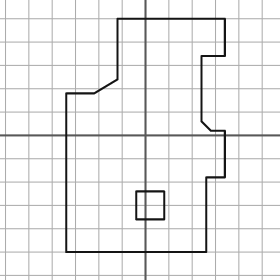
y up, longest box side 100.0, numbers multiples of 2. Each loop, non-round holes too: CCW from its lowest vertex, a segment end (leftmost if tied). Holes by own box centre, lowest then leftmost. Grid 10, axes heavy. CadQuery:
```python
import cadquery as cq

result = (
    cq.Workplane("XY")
    .moveTo(-34.0, -50.0)
    .lineTo(26.0, -50.0)
    .lineTo(26.0, -18.0)
    .lineTo(34.0, -18.0)
    .lineTo(34.0, 2.0)
    .lineTo(28.0, 2.0)
    .lineTo(24.0, 6.0)
    .lineTo(24.0, 34.0)
    .lineTo(34.0, 34.0)
    .lineTo(34.0, 50.0)
    .lineTo(-12.0, 50.0)
    .lineTo(-12.0, 24.0)
    .lineTo(-22.0, 18.0)
    .lineTo(-34.0, 18.0)
    .close()
    .moveTo(-4.0, -36.0)
    .lineTo(8.0, -36.0)
    .lineTo(8.0, -24.0)
    .lineTo(-4.0, -24.0)
    .close()
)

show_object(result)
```